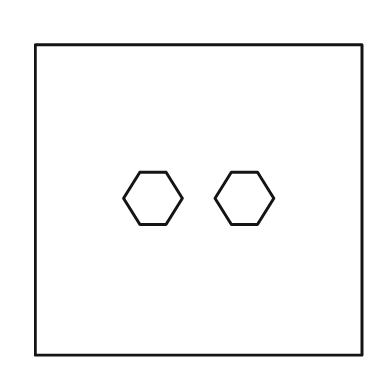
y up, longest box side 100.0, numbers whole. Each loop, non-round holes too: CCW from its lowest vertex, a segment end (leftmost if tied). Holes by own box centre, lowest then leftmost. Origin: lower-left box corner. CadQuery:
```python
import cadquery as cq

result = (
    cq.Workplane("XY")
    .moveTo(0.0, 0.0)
    .lineTo(100.0, 0.0)
    .lineTo(100.0, 95.0)
    .lineTo(0.0, 95.0)
    .close()
    .moveTo(32.0, 40.0)
    .lineTo(40.0, 40.0)
    .lineTo(45.0, 48.0)
    .lineTo(40.0, 56.0)
    .lineTo(32.0, 56.0)
    .lineTo(27.0, 48.0)
    .close()
    .moveTo(60.0, 40.0)
    .lineTo(68.0, 40.0)
    .lineTo(73.0, 48.0)
    .lineTo(68.0, 56.0)
    .lineTo(60.0, 56.0)
    .lineTo(55.0, 48.0)
    .close()
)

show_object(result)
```